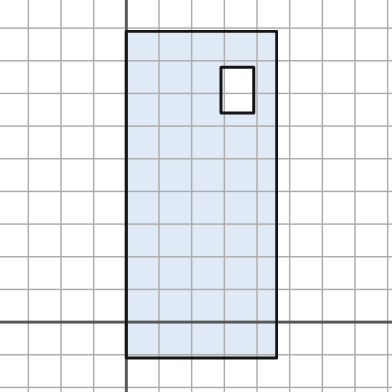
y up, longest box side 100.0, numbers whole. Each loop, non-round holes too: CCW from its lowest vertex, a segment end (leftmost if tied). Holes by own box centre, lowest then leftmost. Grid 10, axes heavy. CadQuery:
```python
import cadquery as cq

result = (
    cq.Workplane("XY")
    .moveTo(0.0, -11.0)
    .lineTo(46.0, -11.0)
    .lineTo(46.0, 89.0)
    .lineTo(0.0, 89.0)
    .close()
    .moveTo(29.0, 64.0)
    .lineTo(39.0, 64.0)
    .lineTo(39.0, 78.0)
    .lineTo(29.0, 78.0)
    .close()
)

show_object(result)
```